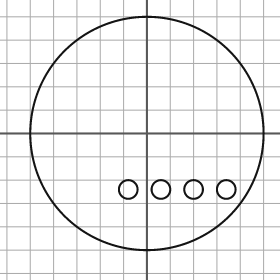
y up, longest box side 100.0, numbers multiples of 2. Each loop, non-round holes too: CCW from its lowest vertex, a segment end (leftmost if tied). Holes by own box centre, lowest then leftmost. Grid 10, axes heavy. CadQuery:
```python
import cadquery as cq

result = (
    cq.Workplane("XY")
    .moveTo(0.0, 0.0)
    .circle(50.0)
    .moveTo(-8.0, -24.0)
    .circle(4.0)
    .moveTo(6.0, -24.0)
    .circle(4.0)
    .moveTo(20.0, -24.0)
    .circle(4.0)
    .moveTo(34.0, -24.0)
    .circle(4.0)
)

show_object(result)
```